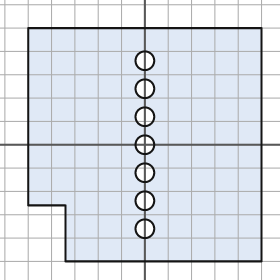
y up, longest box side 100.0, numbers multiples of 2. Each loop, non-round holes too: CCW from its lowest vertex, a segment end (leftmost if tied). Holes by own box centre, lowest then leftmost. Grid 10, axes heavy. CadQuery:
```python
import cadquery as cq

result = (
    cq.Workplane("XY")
    .moveTo(-34.0, -50.0)
    .lineTo(50.0, -50.0)
    .lineTo(50.0, 50.0)
    .lineTo(-50.0, 50.0)
    .lineTo(-50.0, -26.0)
    .lineTo(-34.0, -26.0)
    .close()
    .moveTo(0.0, -36.0)
    .circle(4.0)
    .moveTo(0.0, -24.0)
    .circle(4.0)
    .moveTo(0.0, -12.0)
    .circle(4.0)
    .moveTo(0.0, 0.0)
    .circle(4.0)
    .moveTo(0.0, 12.0)
    .circle(4.0)
    .moveTo(0.0, 24.0)
    .circle(4.0)
    .moveTo(0.0, 36.0)
    .circle(4.0)
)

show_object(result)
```